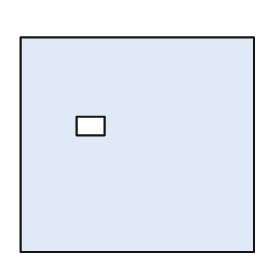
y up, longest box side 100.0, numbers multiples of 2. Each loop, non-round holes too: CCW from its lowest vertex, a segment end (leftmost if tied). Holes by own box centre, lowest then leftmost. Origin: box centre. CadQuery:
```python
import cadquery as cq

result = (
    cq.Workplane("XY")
    .moveTo(-50.0, -46.0)
    .lineTo(50.0, -46.0)
    .lineTo(50.0, 46.0)
    .lineTo(-50.0, 46.0)
    .close()
    .moveTo(-26.0, 4.0)
    .lineTo(-14.0, 4.0)
    .lineTo(-14.0, 12.0)
    .lineTo(-26.0, 12.0)
    .close()
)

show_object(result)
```